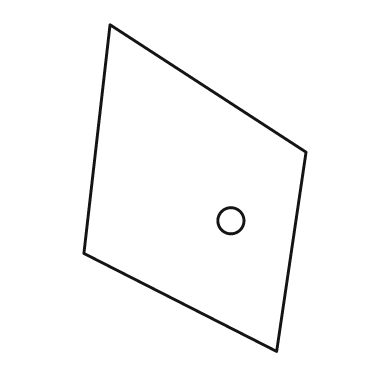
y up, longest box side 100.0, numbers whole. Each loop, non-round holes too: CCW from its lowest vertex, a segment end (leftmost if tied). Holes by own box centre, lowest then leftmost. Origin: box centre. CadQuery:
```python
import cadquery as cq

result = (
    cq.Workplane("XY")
    .moveTo(25.0, -50.0)
    .lineTo(34.0, 11.0)
    .lineTo(-26.0, 50.0)
    .lineTo(-34.0, -20.0)
    .close()
    .moveTo(11.0, -10.0)
    .circle(4.0)
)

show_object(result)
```